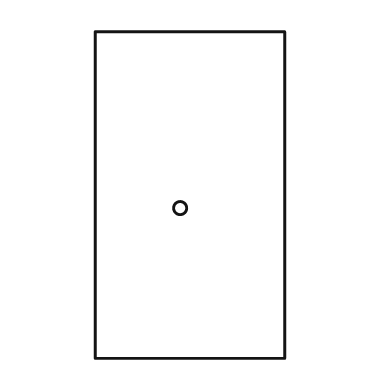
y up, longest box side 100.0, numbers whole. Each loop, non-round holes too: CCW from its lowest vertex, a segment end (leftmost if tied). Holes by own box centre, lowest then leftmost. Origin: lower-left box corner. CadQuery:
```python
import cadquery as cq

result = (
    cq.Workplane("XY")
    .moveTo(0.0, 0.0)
    .lineTo(58.0, 0.0)
    .lineTo(58.0, 100.0)
    .lineTo(0.0, 100.0)
    .close()
    .moveTo(26.0, 46.0)
    .circle(2.0)
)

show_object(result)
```